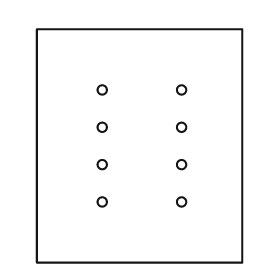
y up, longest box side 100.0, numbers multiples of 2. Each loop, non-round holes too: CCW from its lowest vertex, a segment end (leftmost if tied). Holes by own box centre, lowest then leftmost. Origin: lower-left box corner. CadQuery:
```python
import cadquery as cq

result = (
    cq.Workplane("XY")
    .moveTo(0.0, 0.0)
    .lineTo(88.0, 0.0)
    .lineTo(88.0, 100.0)
    .lineTo(0.0, 100.0)
    .close()
    .moveTo(28.0, 26.0)
    .circle(2.0)
    .moveTo(62.0, 26.0)
    .circle(2.0)
    .moveTo(28.0, 42.0)
    .circle(2.0)
    .moveTo(62.0, 42.0)
    .circle(2.0)
    .moveTo(28.0, 58.0)
    .circle(2.0)
    .moveTo(62.0, 58.0)
    .circle(2.0)
    .moveTo(28.0, 74.0)
    .circle(2.0)
    .moveTo(62.0, 74.0)
    .circle(2.0)
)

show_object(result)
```